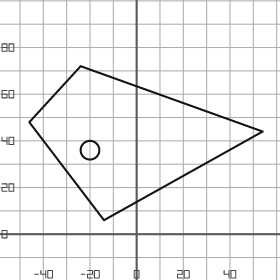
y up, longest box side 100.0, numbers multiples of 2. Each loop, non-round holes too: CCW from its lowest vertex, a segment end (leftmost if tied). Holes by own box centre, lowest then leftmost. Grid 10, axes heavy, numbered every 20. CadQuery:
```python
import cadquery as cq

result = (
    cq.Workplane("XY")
    .moveTo(-14.0, 6.0)
    .lineTo(54.0, 44.0)
    .lineTo(-24.0, 72.0)
    .lineTo(-46.0, 48.0)
    .close()
    .moveTo(-20.0, 36.0)
    .circle(4.0)
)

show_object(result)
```